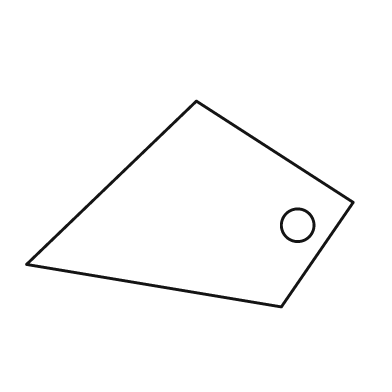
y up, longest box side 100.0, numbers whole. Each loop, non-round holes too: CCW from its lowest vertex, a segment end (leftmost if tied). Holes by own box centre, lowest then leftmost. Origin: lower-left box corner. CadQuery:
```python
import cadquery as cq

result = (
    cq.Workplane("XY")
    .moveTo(78.0, 0.0)
    .lineTo(100.0, 32.0)
    .lineTo(52.0, 63.0)
    .lineTo(0.0, 13.0)
    .close()
    .moveTo(83.0, 25.0)
    .circle(5.0)
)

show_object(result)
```